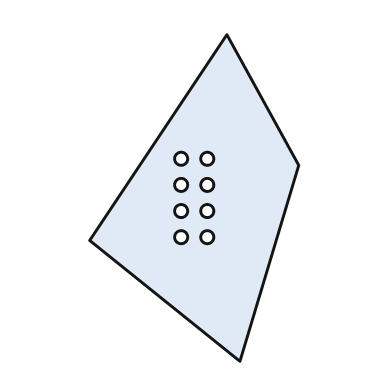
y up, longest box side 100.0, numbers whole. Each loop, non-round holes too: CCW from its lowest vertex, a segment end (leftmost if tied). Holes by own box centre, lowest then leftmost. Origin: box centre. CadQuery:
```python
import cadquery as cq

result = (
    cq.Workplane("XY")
    .moveTo(14.0, -50.0)
    .lineTo(32.0, 10.0)
    .lineTo(10.0, 50.0)
    .lineTo(-32.0, -13.0)
    .close()
    .moveTo(-4.0, -12.0)
    .circle(2.0)
    .moveTo(4.0, -12.0)
    .circle(2.0)
    .moveTo(-4.0, -4.0)
    .circle(2.0)
    .moveTo(4.0, -4.0)
    .circle(2.0)
    .moveTo(-4.0, 4.0)
    .circle(2.0)
    .moveTo(4.0, 4.0)
    .circle(2.0)
    .moveTo(-4.0, 12.0)
    .circle(2.0)
    .moveTo(4.0, 12.0)
    .circle(2.0)
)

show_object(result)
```